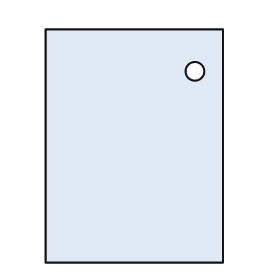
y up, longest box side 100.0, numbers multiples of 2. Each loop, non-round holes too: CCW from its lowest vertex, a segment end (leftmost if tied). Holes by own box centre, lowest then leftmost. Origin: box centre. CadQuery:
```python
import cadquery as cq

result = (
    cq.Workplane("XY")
    .moveTo(-38.0, -50.0)
    .lineTo(38.0, -50.0)
    .lineTo(38.0, 50.0)
    .lineTo(-38.0, 50.0)
    .close()
    .moveTo(26.0, 32.0)
    .circle(4.0)
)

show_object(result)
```